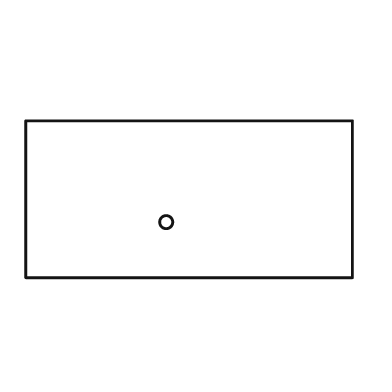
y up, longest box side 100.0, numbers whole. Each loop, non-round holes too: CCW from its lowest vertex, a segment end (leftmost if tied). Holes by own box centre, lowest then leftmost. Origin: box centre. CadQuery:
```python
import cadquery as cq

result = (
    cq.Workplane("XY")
    .moveTo(-50.0, -24.0)
    .lineTo(50.0, -24.0)
    .lineTo(50.0, 24.0)
    .lineTo(-50.0, 24.0)
    .close()
    .moveTo(-7.0, -7.0)
    .circle(2.0)
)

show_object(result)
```